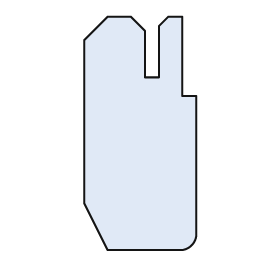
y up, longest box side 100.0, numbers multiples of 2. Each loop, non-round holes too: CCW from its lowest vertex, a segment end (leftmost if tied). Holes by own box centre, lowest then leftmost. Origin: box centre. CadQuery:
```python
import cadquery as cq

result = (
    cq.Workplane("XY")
    .moveTo(-14.0, -50.0)
    .lineTo(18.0, -50.0)
    .threePointArc((22.0, -48.0), (24.0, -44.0))
    .lineTo(24.0, 16.0)
    .lineTo(18.0, 16.0)
    .lineTo(18.0, 50.0)
    .lineTo(12.0, 50.0)
    .lineTo(8.0, 46.0)
    .lineTo(8.0, 24.0)
    .lineTo(2.0, 24.0)
    .lineTo(2.0, 44.0)
    .lineTo(-4.0, 50.0)
    .lineTo(-14.0, 50.0)
    .lineTo(-24.0, 40.0)
    .lineTo(-24.0, -30.0)
    .close()
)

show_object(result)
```